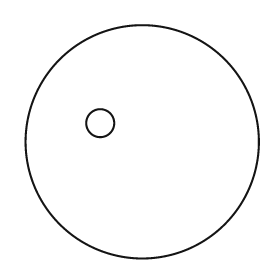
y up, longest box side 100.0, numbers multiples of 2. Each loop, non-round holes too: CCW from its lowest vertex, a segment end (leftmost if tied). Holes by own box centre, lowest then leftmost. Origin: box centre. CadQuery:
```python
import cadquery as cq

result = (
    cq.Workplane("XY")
    .moveTo(0.0, 0.0)
    .circle(50.0)
    .moveTo(-18.0, 8.0)
    .circle(6.0)
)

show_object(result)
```